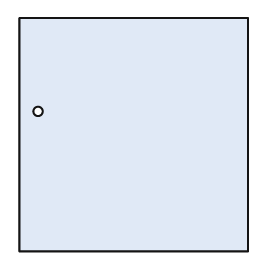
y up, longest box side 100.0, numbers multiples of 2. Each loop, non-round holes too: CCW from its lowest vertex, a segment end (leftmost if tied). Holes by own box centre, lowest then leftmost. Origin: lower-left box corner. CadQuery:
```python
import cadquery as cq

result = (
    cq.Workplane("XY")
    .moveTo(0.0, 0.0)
    .lineTo(98.0, 0.0)
    .lineTo(98.0, 100.0)
    .lineTo(0.0, 100.0)
    .close()
    .moveTo(8.0, 60.0)
    .circle(2.0)
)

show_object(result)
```